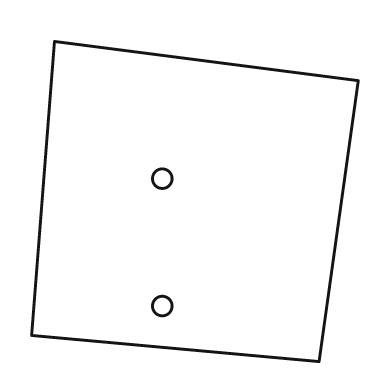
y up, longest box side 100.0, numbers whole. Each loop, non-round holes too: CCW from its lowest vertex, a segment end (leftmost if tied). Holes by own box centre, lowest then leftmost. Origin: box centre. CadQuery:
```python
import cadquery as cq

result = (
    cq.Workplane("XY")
    .moveTo(38.0, -49.0)
    .lineTo(50.0, 37.0)
    .lineTo(-43.0, 49.0)
    .lineTo(-50.0, -41.0)
    .close()
    .moveTo(-10.0, -32.0)
    .circle(3.0)
    .moveTo(-10.0, 7.0)
    .circle(3.0)
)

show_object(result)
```